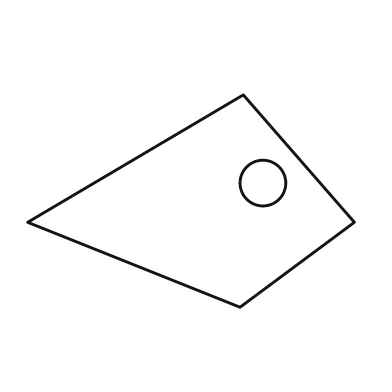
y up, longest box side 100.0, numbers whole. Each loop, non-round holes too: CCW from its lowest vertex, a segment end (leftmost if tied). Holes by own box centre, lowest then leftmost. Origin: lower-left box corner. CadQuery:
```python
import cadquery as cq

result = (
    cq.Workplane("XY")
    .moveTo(65.0, 0.0)
    .lineTo(100.0, 26.0)
    .lineTo(66.0, 65.0)
    .lineTo(0.0, 26.0)
    .close()
    .moveTo(72.0, 38.0)
    .circle(7.0)
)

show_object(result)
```